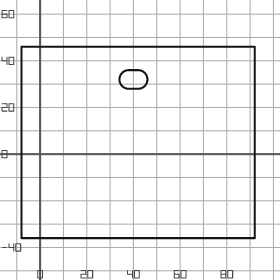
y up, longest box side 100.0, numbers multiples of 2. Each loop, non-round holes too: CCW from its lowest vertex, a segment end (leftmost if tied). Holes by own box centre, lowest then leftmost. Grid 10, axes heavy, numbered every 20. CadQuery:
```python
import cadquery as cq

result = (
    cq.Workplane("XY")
    .moveTo(-8.0, -36.0)
    .lineTo(92.0, -36.0)
    .lineTo(92.0, 46.0)
    .lineTo(-8.0, 46.0)
    .close()
    .moveTo(38.0, 28.0)
    .lineTo(42.0, 28.0)
    .threePointArc((46.0, 32.0), (42.0, 36.0))
    .lineTo(38.0, 36.0)
    .threePointArc((34.0, 32.0), (38.0, 28.0))
    .close()
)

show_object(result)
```